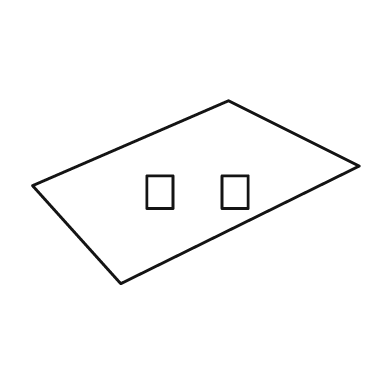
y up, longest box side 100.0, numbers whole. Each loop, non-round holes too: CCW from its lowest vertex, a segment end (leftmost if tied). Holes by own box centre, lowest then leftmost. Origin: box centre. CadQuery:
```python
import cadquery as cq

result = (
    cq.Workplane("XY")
    .moveTo(-23.0, -28.0)
    .lineTo(50.0, 8.0)
    .lineTo(10.0, 28.0)
    .lineTo(-50.0, 2.0)
    .close()
    .moveTo(-15.0, -5.0)
    .lineTo(-7.0, -5.0)
    .lineTo(-7.0, 5.0)
    .lineTo(-15.0, 5.0)
    .close()
    .moveTo(8.0, -5.0)
    .lineTo(16.0, -5.0)
    .lineTo(16.0, 5.0)
    .lineTo(8.0, 5.0)
    .close()
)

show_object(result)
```